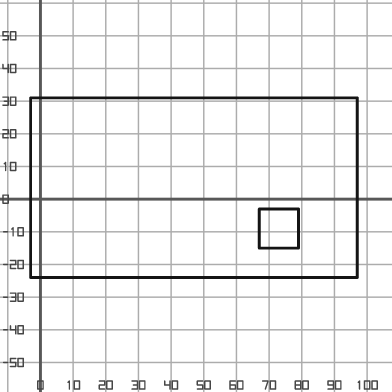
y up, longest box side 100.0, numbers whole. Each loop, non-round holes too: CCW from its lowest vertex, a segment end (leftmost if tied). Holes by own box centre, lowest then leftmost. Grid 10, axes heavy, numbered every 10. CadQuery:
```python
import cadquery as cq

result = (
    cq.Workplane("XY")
    .moveTo(-3.0, -24.0)
    .lineTo(97.0, -24.0)
    .lineTo(97.0, 31.0)
    .lineTo(-3.0, 31.0)
    .close()
    .moveTo(67.0, -15.0)
    .lineTo(79.0, -15.0)
    .lineTo(79.0, -3.0)
    .lineTo(67.0, -3.0)
    .close()
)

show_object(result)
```